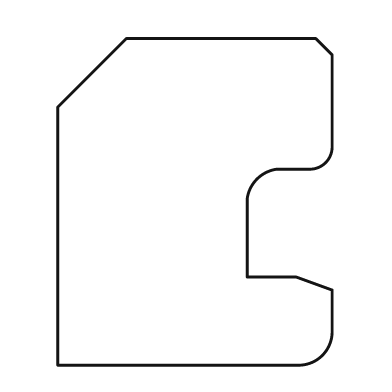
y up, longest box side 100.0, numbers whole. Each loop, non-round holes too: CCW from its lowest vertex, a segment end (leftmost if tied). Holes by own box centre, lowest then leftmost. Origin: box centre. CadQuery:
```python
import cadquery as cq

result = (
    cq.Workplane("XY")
    .moveTo(-42.0, -50.0)
    .lineTo(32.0, -50.0)
    .threePointArc((39.0, -47.0), (42.0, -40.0))
    .lineTo(42.0, -27.0)
    .lineTo(31.0, -23.0)
    .lineTo(16.0, -23.0)
    .lineTo(16.0, 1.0)
    .threePointArc((19.0, 7.0), (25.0, 10.0))
    .lineTo(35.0, 10.0)
    .threePointArc((40.0, 12.0), (42.0, 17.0))
    .lineTo(42.0, 45.0)
    .lineTo(37.0, 50.0)
    .lineTo(-21.0, 50.0)
    .lineTo(-42.0, 29.0)
    .close()
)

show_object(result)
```